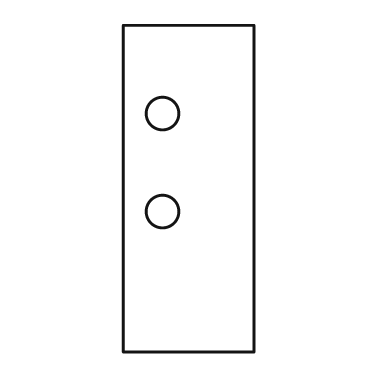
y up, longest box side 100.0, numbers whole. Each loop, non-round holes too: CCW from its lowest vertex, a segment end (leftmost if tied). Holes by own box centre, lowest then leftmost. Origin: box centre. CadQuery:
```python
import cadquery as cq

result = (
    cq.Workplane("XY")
    .moveTo(-20.0, -50.0)
    .lineTo(20.0, -50.0)
    .lineTo(20.0, 50.0)
    .lineTo(-20.0, 50.0)
    .close()
    .moveTo(-8.0, -7.0)
    .circle(5.0)
    .moveTo(-8.0, 23.0)
    .circle(5.0)
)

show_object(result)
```